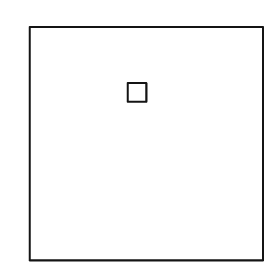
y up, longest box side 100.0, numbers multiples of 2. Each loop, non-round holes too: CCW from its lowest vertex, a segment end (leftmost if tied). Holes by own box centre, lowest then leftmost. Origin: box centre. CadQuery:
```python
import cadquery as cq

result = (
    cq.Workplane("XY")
    .moveTo(-50.0, -50.0)
    .lineTo(50.0, -50.0)
    .lineTo(50.0, 50.0)
    .lineTo(-50.0, 50.0)
    .close()
    .moveTo(-8.0, 18.0)
    .lineTo(0.0, 18.0)
    .lineTo(0.0, 26.0)
    .lineTo(-8.0, 26.0)
    .close()
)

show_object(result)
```